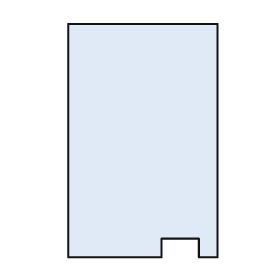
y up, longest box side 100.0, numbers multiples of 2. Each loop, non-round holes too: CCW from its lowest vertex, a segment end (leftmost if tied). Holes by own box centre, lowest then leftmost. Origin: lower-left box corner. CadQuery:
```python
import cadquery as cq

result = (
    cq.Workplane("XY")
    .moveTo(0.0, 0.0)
    .lineTo(40.0, 0.0)
    .lineTo(40.0, 8.0)
    .lineTo(56.0, 8.0)
    .lineTo(56.0, 0.0)
    .lineTo(64.0, 0.0)
    .lineTo(64.0, 100.0)
    .lineTo(0.0, 100.0)
    .close()
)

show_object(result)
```